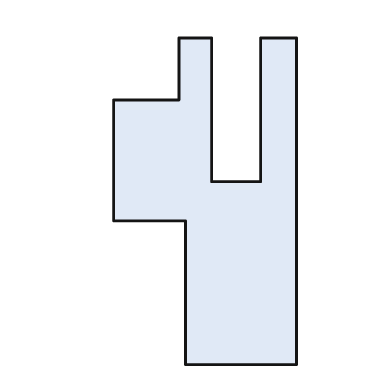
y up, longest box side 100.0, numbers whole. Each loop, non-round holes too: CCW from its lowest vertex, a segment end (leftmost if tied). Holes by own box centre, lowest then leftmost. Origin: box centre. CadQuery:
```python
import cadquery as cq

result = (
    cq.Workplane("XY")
    .moveTo(-6.0, -50.0)
    .lineTo(28.0, -50.0)
    .lineTo(28.0, 50.0)
    .lineTo(17.0, 50.0)
    .lineTo(17.0, 6.0)
    .lineTo(2.0, 6.0)
    .lineTo(2.0, 50.0)
    .lineTo(-8.0, 50.0)
    .lineTo(-8.0, 31.0)
    .lineTo(-28.0, 31.0)
    .lineTo(-28.0, -6.0)
    .lineTo(-6.0, -6.0)
    .close()
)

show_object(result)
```